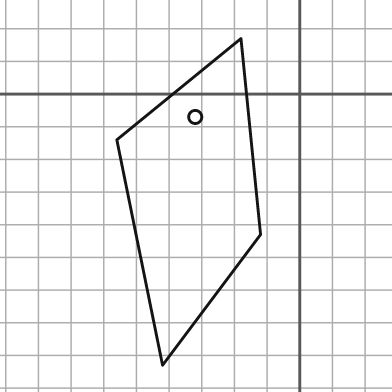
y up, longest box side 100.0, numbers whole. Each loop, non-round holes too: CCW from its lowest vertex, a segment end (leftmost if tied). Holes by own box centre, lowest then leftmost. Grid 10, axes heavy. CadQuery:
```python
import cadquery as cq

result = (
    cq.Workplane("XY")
    .moveTo(-42.0, -83.0)
    .lineTo(-12.0, -43.0)
    .lineTo(-18.0, 17.0)
    .lineTo(-56.0, -14.0)
    .close()
    .moveTo(-32.0, -7.0)
    .circle(2.0)
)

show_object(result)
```